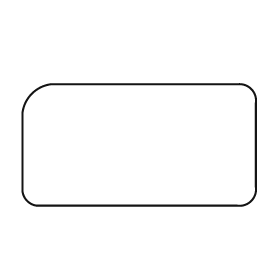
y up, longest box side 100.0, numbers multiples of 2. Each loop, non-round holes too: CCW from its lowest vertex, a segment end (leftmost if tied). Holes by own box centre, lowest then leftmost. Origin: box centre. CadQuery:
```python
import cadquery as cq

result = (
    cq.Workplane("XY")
    .moveTo(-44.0, -26.0)
    .lineTo(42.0, -26.0)
    .threePointArc((48.0, -24.0), (50.0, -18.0))
    .lineTo(50.0, 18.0)
    .threePointArc((48.0, 24.0), (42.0, 26.0))
    .lineTo(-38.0, 26.0)
    .threePointArc((-46.0, 22.0), (-50.0, 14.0))
    .lineTo(-50.0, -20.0)
    .threePointArc((-48.0, -24.0), (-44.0, -26.0))
    .close()
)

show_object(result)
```